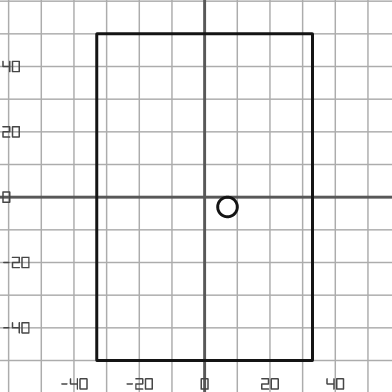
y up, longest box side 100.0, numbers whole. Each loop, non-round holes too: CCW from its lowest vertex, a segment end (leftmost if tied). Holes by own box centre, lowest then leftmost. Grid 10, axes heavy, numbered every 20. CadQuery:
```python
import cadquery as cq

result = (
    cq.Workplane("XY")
    .moveTo(-33.0, -50.0)
    .lineTo(33.0, -50.0)
    .lineTo(33.0, 50.0)
    .lineTo(-33.0, 50.0)
    .close()
    .moveTo(7.0, -3.0)
    .circle(3.0)
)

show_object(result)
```